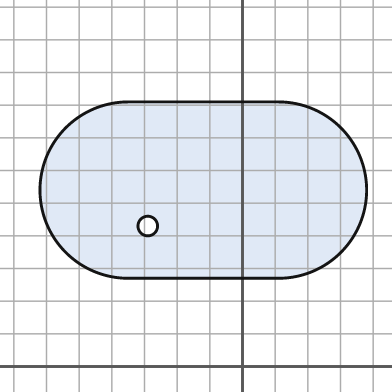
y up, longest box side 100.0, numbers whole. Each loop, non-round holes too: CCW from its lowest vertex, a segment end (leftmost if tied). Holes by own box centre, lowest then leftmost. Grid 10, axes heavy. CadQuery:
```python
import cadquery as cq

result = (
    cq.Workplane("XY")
    .moveTo(-35.0, 27.0)
    .lineTo(11.0, 27.0)
    .threePointArc((38.0, 54.0), (11.0, 81.0))
    .lineTo(-35.0, 81.0)
    .threePointArc((-62.0, 54.0), (-35.0, 27.0))
    .close()
    .moveTo(-29.0, 43.0)
    .circle(3.0)
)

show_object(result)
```